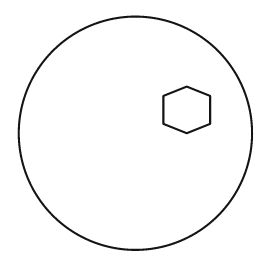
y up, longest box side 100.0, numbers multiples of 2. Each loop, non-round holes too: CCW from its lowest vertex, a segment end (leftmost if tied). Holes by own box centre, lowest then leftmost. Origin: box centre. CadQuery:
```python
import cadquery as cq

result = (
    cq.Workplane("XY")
    .moveTo(0.0, 0.0)
    .circle(50.0)
    .moveTo(22.0, 0.0)
    .lineTo(32.0, 4.0)
    .lineTo(32.0, 16.0)
    .lineTo(22.0, 20.0)
    .lineTo(12.0, 16.0)
    .lineTo(12.0, 4.0)
    .close()
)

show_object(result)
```